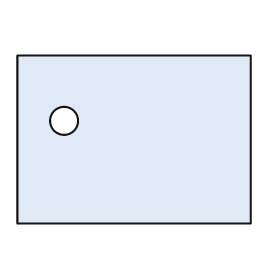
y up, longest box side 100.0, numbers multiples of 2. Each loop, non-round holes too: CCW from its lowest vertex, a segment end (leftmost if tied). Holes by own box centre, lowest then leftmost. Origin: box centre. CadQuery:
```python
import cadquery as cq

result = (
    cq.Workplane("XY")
    .moveTo(-50.0, -36.0)
    .lineTo(50.0, -36.0)
    .lineTo(50.0, 36.0)
    .lineTo(-50.0, 36.0)
    .close()
    .moveTo(-30.0, 8.0)
    .circle(6.0)
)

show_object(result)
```